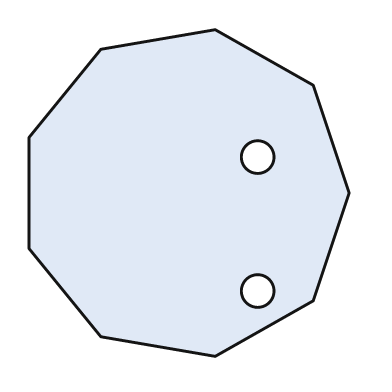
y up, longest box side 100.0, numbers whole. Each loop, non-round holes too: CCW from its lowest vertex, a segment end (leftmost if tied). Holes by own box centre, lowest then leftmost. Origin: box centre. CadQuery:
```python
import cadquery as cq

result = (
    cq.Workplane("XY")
    .moveTo(8.0, -50.0)
    .lineTo(38.0, -33.0)
    .lineTo(49.0, 0.0)
    .lineTo(38.0, 33.0)
    .lineTo(8.0, 50.0)
    .lineTo(-27.0, 44.0)
    .lineTo(-49.0, 17.0)
    .lineTo(-49.0, -17.0)
    .lineTo(-27.0, -44.0)
    .close()
    .moveTo(21.0, -30.0)
    .circle(5.0)
    .moveTo(21.0, 11.0)
    .circle(5.0)
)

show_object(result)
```